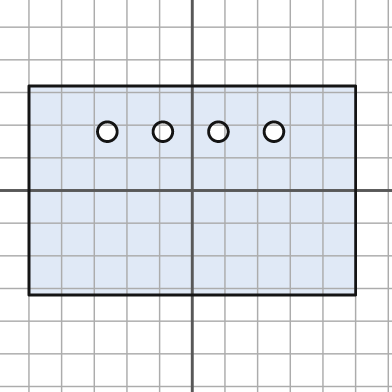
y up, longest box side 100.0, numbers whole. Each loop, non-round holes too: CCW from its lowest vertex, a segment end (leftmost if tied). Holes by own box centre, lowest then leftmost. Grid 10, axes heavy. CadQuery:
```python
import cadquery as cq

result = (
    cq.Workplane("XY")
    .moveTo(-50.0, -32.0)
    .lineTo(50.0, -32.0)
    .lineTo(50.0, 32.0)
    .lineTo(-50.0, 32.0)
    .close()
    .moveTo(-26.0, 18.0)
    .circle(3.0)
    .moveTo(-9.0, 18.0)
    .circle(3.0)
    .moveTo(8.0, 18.0)
    .circle(3.0)
    .moveTo(25.0, 18.0)
    .circle(3.0)
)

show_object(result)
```